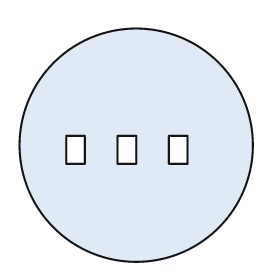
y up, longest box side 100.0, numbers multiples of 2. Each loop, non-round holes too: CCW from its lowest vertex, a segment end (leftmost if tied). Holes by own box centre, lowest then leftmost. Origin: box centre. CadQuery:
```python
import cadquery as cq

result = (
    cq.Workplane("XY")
    .moveTo(0.0, 0.0)
    .circle(50.0)
    .moveTo(-30.0, -8.0)
    .lineTo(-22.0, -8.0)
    .lineTo(-22.0, 4.0)
    .lineTo(-30.0, 4.0)
    .close()
    .moveTo(-8.0, -8.0)
    .lineTo(0.0, -8.0)
    .lineTo(0.0, 4.0)
    .lineTo(-8.0, 4.0)
    .close()
    .moveTo(14.0, -8.0)
    .lineTo(22.0, -8.0)
    .lineTo(22.0, 4.0)
    .lineTo(14.0, 4.0)
    .close()
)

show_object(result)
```